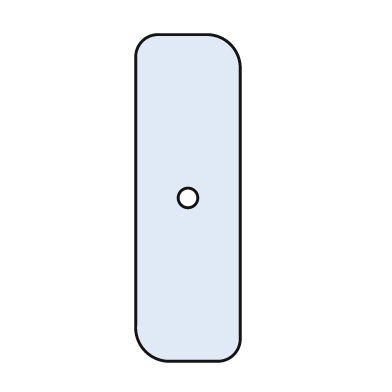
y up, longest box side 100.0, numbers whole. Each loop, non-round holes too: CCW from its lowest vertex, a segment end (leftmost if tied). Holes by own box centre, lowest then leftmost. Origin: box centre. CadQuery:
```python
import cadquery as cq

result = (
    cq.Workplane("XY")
    .moveTo(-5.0, -50.0)
    .lineTo(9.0, -50.0)
    .threePointArc((14.0, -48.0), (16.0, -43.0))
    .lineTo(16.0, 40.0)
    .threePointArc((13.0, 47.0), (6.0, 50.0))
    .lineTo(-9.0, 50.0)
    .threePointArc((-14.0, 48.0), (-16.0, 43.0))
    .lineTo(-16.0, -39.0)
    .threePointArc((-13.0, -47.0), (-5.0, -50.0))
    .close()
    .moveTo(0.0, 0.0)
    .circle(3.0)
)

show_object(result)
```